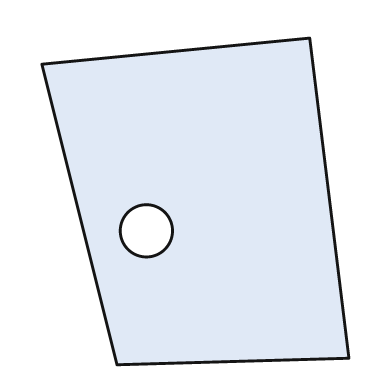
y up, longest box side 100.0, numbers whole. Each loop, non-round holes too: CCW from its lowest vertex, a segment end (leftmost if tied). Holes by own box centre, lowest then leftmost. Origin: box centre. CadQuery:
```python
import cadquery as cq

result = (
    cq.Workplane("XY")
    .moveTo(-24.0, -50.0)
    .lineTo(47.0, -48.0)
    .lineTo(35.0, 50.0)
    .lineTo(-47.0, 42.0)
    .close()
    .moveTo(-15.0, -9.0)
    .circle(8.0)
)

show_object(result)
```